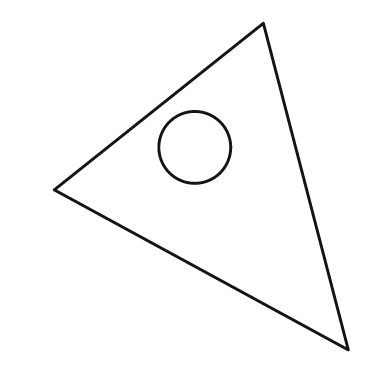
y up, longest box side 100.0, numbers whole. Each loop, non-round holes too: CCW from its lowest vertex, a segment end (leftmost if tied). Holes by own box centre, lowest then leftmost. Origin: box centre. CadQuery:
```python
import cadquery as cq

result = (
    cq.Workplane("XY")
    .moveTo(45.0, -50.0)
    .lineTo(19.0, 50.0)
    .lineTo(-45.0, -1.0)
    .close()
    .moveTo(-2.0, 12.0)
    .circle(11.0)
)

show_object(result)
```